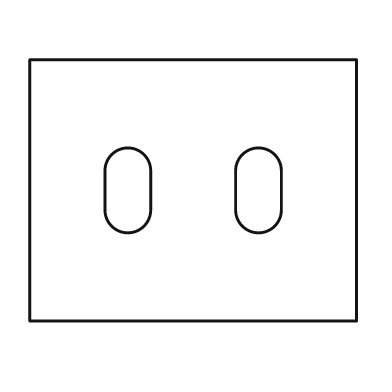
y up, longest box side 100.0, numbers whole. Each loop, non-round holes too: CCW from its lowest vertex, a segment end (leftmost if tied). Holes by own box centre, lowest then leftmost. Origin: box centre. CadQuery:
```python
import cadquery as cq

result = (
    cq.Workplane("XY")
    .moveTo(-50.0, -40.0)
    .lineTo(50.0, -40.0)
    .lineTo(50.0, 40.0)
    .lineTo(-50.0, 40.0)
    .close()
    .moveTo(-27.0, -6.0)
    .threePointArc((-20.0, -13.0), (-13.0, -6.0))
    .lineTo(-13.0, 6.0)
    .threePointArc((-20.0, 13.0), (-27.0, 6.0))
    .close()
    .moveTo(13.0, -6.0)
    .threePointArc((20.0, -13.0), (27.0, -6.0))
    .lineTo(27.0, 6.0)
    .threePointArc((20.0, 13.0), (13.0, 6.0))
    .close()
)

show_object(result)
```